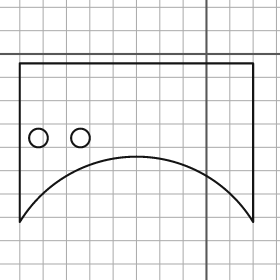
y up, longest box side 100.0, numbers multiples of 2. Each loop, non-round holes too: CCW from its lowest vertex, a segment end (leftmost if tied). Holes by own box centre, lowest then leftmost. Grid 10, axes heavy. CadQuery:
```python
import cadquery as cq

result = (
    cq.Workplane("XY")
    .moveTo(-80.0, -72.0)
    .threePointArc((-30.0, -44.0), (20.0, -72.0))
    .lineTo(20.0, -4.0)
    .lineTo(-80.0, -4.0)
    .close()
    .moveTo(-72.0, -36.0)
    .circle(4.0)
    .moveTo(-54.0, -36.0)
    .circle(4.0)
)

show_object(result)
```